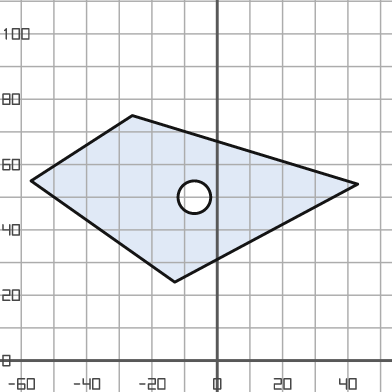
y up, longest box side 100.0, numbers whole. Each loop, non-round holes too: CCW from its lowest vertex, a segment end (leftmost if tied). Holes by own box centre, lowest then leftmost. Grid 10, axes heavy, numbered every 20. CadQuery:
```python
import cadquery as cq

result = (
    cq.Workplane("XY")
    .moveTo(-13.0, 24.0)
    .lineTo(43.0, 54.0)
    .lineTo(-26.0, 75.0)
    .lineTo(-57.0, 55.0)
    .close()
    .moveTo(-7.0, 50.0)
    .circle(5.0)
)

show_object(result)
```